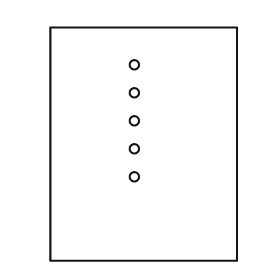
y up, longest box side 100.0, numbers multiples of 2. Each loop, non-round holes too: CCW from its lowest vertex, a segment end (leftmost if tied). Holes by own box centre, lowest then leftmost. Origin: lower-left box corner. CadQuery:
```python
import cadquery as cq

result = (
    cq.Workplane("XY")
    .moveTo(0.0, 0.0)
    .lineTo(80.0, 0.0)
    .lineTo(80.0, 100.0)
    .lineTo(0.0, 100.0)
    .close()
    .moveTo(36.0, 36.0)
    .circle(2.0)
    .moveTo(36.0, 48.0)
    .circle(2.0)
    .moveTo(36.0, 60.0)
    .circle(2.0)
    .moveTo(36.0, 72.0)
    .circle(2.0)
    .moveTo(36.0, 84.0)
    .circle(2.0)
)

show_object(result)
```